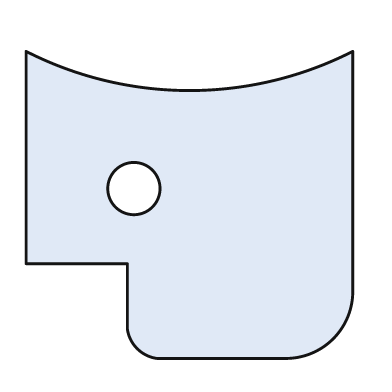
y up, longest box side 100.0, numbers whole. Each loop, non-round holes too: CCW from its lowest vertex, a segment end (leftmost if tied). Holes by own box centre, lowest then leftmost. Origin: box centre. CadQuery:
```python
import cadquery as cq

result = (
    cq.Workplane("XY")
    .moveTo(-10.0, -47.0)
    .lineTo(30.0, -47.0)
    .threePointArc((44.0, -41.0), (50.0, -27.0))
    .lineTo(50.0, 47.0)
    .threePointArc((0.0, 35.0), (-50.0, 47.0))
    .lineTo(-50.0, -18.0)
    .lineTo(-19.0, -18.0)
    .lineTo(-19.0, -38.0)
    .threePointArc((-16.0, -44.0), (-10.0, -47.0))
    .close()
    .moveTo(-17.0, 5.0)
    .circle(8.0)
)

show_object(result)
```